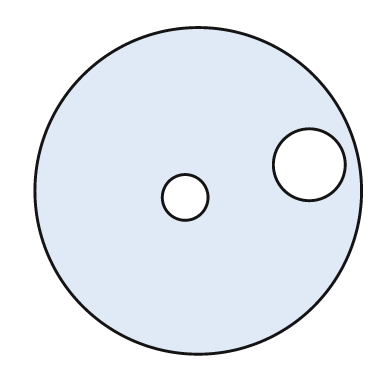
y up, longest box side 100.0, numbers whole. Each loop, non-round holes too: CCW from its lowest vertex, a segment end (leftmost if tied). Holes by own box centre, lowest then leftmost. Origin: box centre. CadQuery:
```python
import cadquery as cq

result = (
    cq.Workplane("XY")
    .moveTo(0.0, 0.0)
    .circle(50.0)
    .moveTo(-4.0, -2.0)
    .circle(7.0)
    .moveTo(34.0, 8.0)
    .circle(11.0)
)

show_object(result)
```